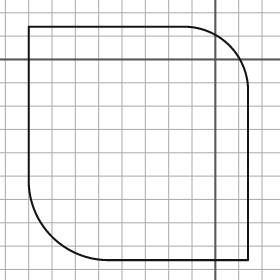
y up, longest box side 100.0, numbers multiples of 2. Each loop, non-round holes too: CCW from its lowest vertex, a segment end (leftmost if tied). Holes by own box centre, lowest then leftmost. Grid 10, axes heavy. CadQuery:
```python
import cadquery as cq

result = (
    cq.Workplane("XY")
    .moveTo(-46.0, -86.0)
    .lineTo(14.0, -86.0)
    .lineTo(14.0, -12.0)
    .threePointArc((6.0, 6.0), (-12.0, 14.0))
    .lineTo(-80.0, 14.0)
    .lineTo(-80.0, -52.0)
    .threePointArc((-70.0, -76.0), (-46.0, -86.0))
    .close()
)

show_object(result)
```